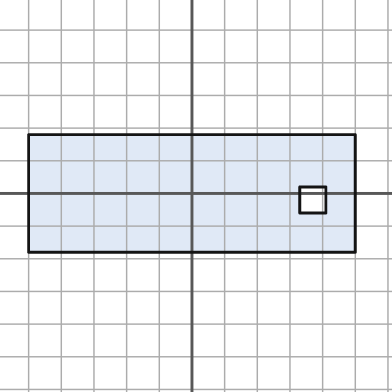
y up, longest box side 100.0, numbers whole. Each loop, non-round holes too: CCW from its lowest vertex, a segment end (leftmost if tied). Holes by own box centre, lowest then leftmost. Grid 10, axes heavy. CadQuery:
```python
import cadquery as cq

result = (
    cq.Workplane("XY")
    .moveTo(-50.0, -18.0)
    .lineTo(50.0, -18.0)
    .lineTo(50.0, 18.0)
    .lineTo(-50.0, 18.0)
    .close()
    .moveTo(33.0, -6.0)
    .lineTo(41.0, -6.0)
    .lineTo(41.0, 2.0)
    .lineTo(33.0, 2.0)
    .close()
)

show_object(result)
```